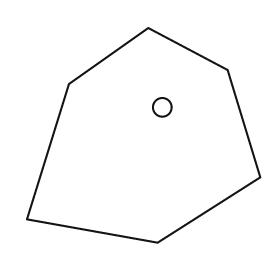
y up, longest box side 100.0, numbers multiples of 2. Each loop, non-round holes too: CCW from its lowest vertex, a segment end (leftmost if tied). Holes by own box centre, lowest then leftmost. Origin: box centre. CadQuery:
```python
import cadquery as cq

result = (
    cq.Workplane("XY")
    .moveTo(6.0, -46.0)
    .lineTo(50.0, -18.0)
    .lineTo(36.0, 28.0)
    .lineTo(2.0, 46.0)
    .lineTo(-32.0, 22.0)
    .lineTo(-50.0, -36.0)
    .close()
    .moveTo(8.0, 12.0)
    .circle(4.0)
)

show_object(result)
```